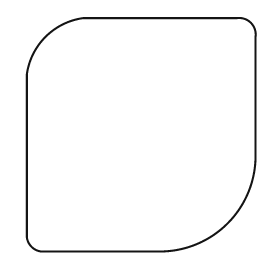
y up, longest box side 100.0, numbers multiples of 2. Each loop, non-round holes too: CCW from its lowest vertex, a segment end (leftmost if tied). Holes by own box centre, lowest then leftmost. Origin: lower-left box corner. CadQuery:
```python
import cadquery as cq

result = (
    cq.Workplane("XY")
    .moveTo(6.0, 0.0)
    .lineTo(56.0, 0.0)
    .threePointArc((86.0, 12.0), (98.0, 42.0))
    .lineTo(98.0, 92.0)
    .threePointArc((96.0, 98.0), (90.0, 100.0))
    .lineTo(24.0, 100.0)
    .threePointArc((8.0, 92.0), (0.0, 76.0))
    .lineTo(0.0, 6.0)
    .threePointArc((2.0, 2.0), (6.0, 0.0))
    .close()
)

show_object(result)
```